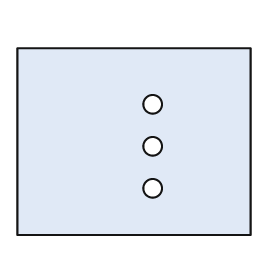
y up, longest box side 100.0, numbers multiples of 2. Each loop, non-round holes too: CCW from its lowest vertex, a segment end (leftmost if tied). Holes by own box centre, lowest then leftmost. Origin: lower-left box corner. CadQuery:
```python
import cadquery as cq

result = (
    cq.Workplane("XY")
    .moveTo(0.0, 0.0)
    .lineTo(100.0, 0.0)
    .lineTo(100.0, 80.0)
    .lineTo(0.0, 80.0)
    .close()
    .moveTo(58.0, 20.0)
    .circle(4.0)
    .moveTo(58.0, 38.0)
    .circle(4.0)
    .moveTo(58.0, 56.0)
    .circle(4.0)
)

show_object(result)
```